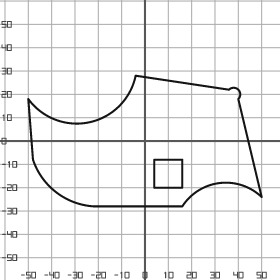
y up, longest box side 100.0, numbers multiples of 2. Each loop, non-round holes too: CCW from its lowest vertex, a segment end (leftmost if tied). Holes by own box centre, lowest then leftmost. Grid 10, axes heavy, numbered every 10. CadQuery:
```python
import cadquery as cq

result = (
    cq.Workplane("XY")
    .moveTo(-22.0, -28.0)
    .lineTo(16.0, -28.0)
    .threePointArc((32.0, -18.0), (50.0, -24.0))
    .lineTo(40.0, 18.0)
    .threePointArc((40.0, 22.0), (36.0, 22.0))
    .lineTo(-4.0, 28.0)
    .threePointArc((-24.0, 8.0), (-50.0, 18.0))
    .lineTo(-48.0, -8.0)
    .threePointArc((-38.0, -22.0), (-22.0, -28.0))
    .close()
    .moveTo(4.0, -20.0)
    .lineTo(16.0, -20.0)
    .lineTo(16.0, -8.0)
    .lineTo(4.0, -8.0)
    .close()
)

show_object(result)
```